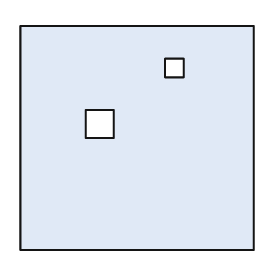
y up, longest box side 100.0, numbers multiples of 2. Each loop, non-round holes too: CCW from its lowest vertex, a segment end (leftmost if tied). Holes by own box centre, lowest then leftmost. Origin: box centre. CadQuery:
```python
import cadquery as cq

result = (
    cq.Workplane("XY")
    .moveTo(-50.0, -48.0)
    .lineTo(50.0, -48.0)
    .lineTo(50.0, 48.0)
    .lineTo(-50.0, 48.0)
    .close()
    .moveTo(-22.0, 0.0)
    .lineTo(-10.0, 0.0)
    .lineTo(-10.0, 12.0)
    .lineTo(-22.0, 12.0)
    .close()
    .moveTo(12.0, 26.0)
    .lineTo(20.0, 26.0)
    .lineTo(20.0, 34.0)
    .lineTo(12.0, 34.0)
    .close()
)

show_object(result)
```